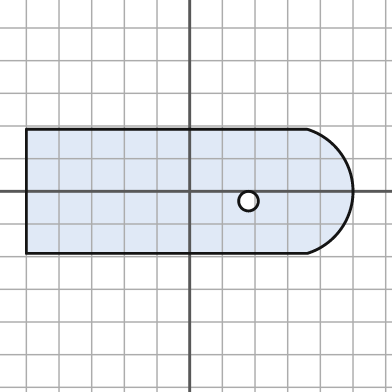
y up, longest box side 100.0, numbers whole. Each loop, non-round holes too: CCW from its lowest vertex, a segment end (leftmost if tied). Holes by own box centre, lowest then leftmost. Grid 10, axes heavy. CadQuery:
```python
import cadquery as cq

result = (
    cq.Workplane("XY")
    .moveTo(-50.0, -19.0)
    .lineTo(36.0, -19.0)
    .threePointArc((50.0, 0.0), (36.0, 19.0))
    .lineTo(-50.0, 19.0)
    .close()
    .moveTo(18.0, -3.0)
    .circle(3.0)
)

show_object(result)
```